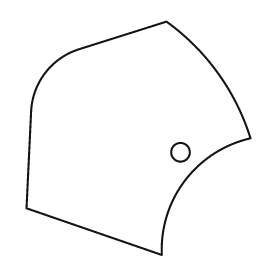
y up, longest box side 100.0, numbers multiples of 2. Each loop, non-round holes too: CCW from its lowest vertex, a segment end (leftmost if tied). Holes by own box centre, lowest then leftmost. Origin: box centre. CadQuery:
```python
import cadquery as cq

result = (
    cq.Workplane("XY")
    .moveTo(10.0, -50.0)
    .threePointArc((20.0, -18.0), (48.0, 0.0))
    .threePointArc((34.0, 28.0), (12.0, 50.0))
    .lineTo(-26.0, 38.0)
    .threePointArc((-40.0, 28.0), (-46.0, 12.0))
    .lineTo(-48.0, -30.0)
    .close()
    .moveTo(18.0, -6.0)
    .circle(4.0)
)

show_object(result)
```